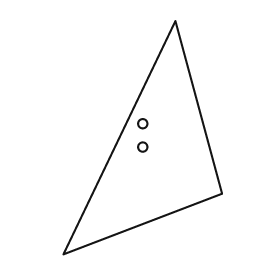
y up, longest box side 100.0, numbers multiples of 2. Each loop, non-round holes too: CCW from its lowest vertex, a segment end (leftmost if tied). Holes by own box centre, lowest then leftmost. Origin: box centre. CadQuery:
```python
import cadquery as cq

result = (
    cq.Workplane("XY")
    .moveTo(-34.0, -50.0)
    .lineTo(34.0, -24.0)
    .lineTo(14.0, 50.0)
    .close()
    .moveTo(0.0, -4.0)
    .circle(2.0)
    .moveTo(0.0, 6.0)
    .circle(2.0)
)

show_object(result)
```